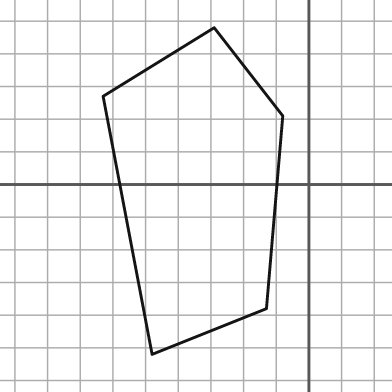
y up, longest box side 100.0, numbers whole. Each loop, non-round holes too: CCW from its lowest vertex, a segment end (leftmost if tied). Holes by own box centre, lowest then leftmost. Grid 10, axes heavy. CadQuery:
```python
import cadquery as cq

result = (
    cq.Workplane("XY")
    .moveTo(-48.0, -52.0)
    .lineTo(-13.0, -38.0)
    .lineTo(-8.0, 21.0)
    .lineTo(-29.0, 48.0)
    .lineTo(-63.0, 27.0)
    .close()
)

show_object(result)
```